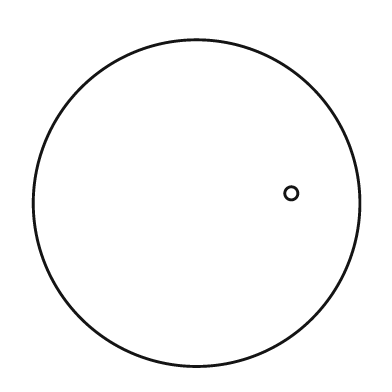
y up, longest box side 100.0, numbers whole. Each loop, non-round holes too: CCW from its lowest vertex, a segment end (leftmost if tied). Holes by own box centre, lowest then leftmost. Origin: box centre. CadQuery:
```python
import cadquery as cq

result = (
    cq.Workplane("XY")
    .moveTo(0.0, 0.0)
    .circle(50.0)
    .moveTo(29.0, 3.0)
    .circle(2.0)
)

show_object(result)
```